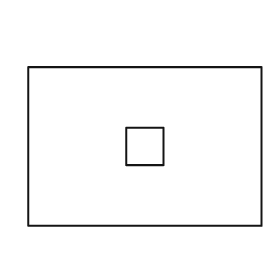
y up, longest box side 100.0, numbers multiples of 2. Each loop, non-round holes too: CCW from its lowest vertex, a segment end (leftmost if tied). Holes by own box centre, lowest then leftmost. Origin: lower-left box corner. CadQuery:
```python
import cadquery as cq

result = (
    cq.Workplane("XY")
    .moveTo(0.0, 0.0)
    .lineTo(100.0, 0.0)
    .lineTo(100.0, 68.0)
    .lineTo(0.0, 68.0)
    .close()
    .moveTo(42.0, 26.0)
    .lineTo(58.0, 26.0)
    .lineTo(58.0, 42.0)
    .lineTo(42.0, 42.0)
    .close()
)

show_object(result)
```